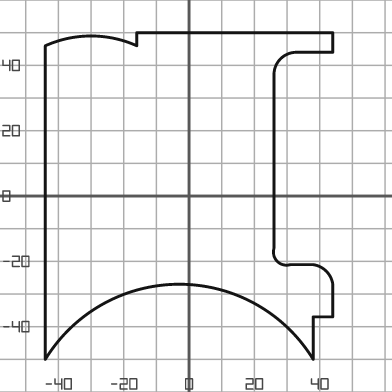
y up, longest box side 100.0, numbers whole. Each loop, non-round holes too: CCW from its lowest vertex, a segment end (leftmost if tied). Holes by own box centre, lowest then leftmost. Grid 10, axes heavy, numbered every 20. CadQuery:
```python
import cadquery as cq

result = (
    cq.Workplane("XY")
    .moveTo(-44.0, -50.0)
    .threePointArc((-3.0, -27.0), (38.0, -50.0))
    .lineTo(38.0, -37.0)
    .lineTo(44.0, -37.0)
    .lineTo(44.0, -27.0)
    .threePointArc((42.0, -23.0), (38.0, -21.0))
    .lineTo(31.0, -21.0)
    .threePointArc((27.0, -20.0), (26.0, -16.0))
    .lineTo(26.0, 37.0)
    .threePointArc((28.0, 42.0), (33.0, 44.0))
    .lineTo(44.0, 44.0)
    .lineTo(44.0, 50.0)
    .lineTo(-16.0, 50.0)
    .lineTo(-16.0, 46.0)
    .threePointArc((-30.0, 49.0), (-44.0, 46.0))
    .close()
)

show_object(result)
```